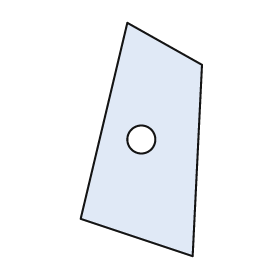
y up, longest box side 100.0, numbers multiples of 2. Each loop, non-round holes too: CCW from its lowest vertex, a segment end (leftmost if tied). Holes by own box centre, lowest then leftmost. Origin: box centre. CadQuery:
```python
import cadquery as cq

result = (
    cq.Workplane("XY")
    .moveTo(22.0, -50.0)
    .lineTo(26.0, 32.0)
    .lineTo(-6.0, 50.0)
    .lineTo(-26.0, -34.0)
    .close()
    .moveTo(0.0, 0.0)
    .circle(6.0)
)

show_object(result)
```